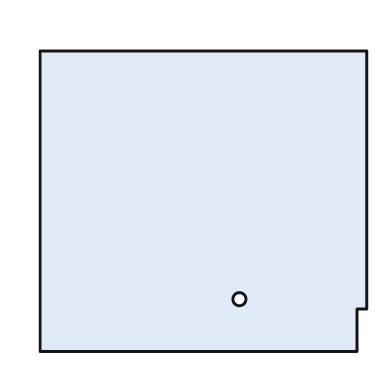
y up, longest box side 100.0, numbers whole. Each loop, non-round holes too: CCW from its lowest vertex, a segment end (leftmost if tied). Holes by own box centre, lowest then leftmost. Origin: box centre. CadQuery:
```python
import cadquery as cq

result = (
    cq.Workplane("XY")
    .moveTo(-50.0, -46.0)
    .lineTo(47.0, -46.0)
    .lineTo(47.0, -33.0)
    .lineTo(50.0, -33.0)
    .lineTo(50.0, 46.0)
    .lineTo(-50.0, 46.0)
    .close()
    .moveTo(11.0, -30.0)
    .circle(2.0)
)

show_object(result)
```